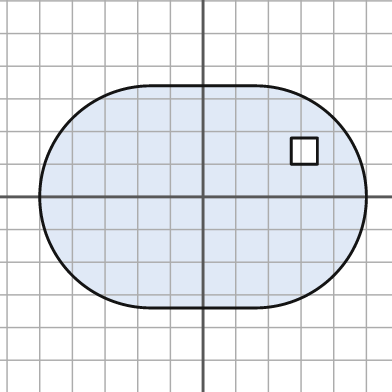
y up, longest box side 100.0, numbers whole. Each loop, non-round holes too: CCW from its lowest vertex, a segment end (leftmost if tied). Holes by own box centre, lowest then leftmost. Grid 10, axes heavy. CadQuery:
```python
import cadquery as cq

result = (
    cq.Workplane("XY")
    .moveTo(-16.0, -34.0)
    .lineTo(16.0, -34.0)
    .threePointArc((50.0, 0.0), (16.0, 34.0))
    .lineTo(-16.0, 34.0)
    .threePointArc((-50.0, 0.0), (-16.0, -34.0))
    .close()
    .moveTo(27.0, 10.0)
    .lineTo(35.0, 10.0)
    .lineTo(35.0, 18.0)
    .lineTo(27.0, 18.0)
    .close()
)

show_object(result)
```